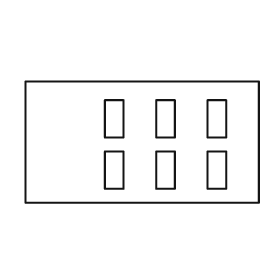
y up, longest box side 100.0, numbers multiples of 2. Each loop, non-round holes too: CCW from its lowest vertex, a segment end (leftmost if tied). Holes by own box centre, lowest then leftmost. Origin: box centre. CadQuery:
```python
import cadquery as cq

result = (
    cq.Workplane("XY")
    .moveTo(-50.0, -26.0)
    .lineTo(50.0, -26.0)
    .lineTo(50.0, 26.0)
    .lineTo(-50.0, 26.0)
    .close()
    .moveTo(-16.0, -20.0)
    .lineTo(-8.0, -20.0)
    .lineTo(-8.0, -4.0)
    .lineTo(-16.0, -4.0)
    .close()
    .moveTo(6.0, -20.0)
    .lineTo(14.0, -20.0)
    .lineTo(14.0, -4.0)
    .lineTo(6.0, -4.0)
    .close()
    .moveTo(28.0, -20.0)
    .lineTo(36.0, -20.0)
    .lineTo(36.0, -4.0)
    .lineTo(28.0, -4.0)
    .close()
    .moveTo(-16.0, 2.0)
    .lineTo(-8.0, 2.0)
    .lineTo(-8.0, 18.0)
    .lineTo(-16.0, 18.0)
    .close()
    .moveTo(6.0, 2.0)
    .lineTo(14.0, 2.0)
    .lineTo(14.0, 18.0)
    .lineTo(6.0, 18.0)
    .close()
    .moveTo(28.0, 2.0)
    .lineTo(36.0, 2.0)
    .lineTo(36.0, 18.0)
    .lineTo(28.0, 18.0)
    .close()
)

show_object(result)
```